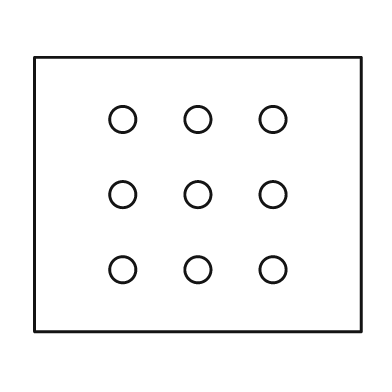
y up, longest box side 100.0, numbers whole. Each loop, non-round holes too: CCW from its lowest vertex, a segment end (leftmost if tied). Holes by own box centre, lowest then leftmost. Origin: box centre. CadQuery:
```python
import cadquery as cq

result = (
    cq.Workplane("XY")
    .moveTo(-50.0, -42.0)
    .lineTo(50.0, -42.0)
    .lineTo(50.0, 42.0)
    .lineTo(-50.0, 42.0)
    .close()
    .moveTo(-23.0, -23.0)
    .circle(4.0)
    .moveTo(0.0, -23.0)
    .circle(4.0)
    .moveTo(23.0, -23.0)
    .circle(4.0)
    .moveTo(-23.0, 0.0)
    .circle(4.0)
    .moveTo(0.0, 0.0)
    .circle(4.0)
    .moveTo(23.0, 0.0)
    .circle(4.0)
    .moveTo(-23.0, 23.0)
    .circle(4.0)
    .moveTo(0.0, 23.0)
    .circle(4.0)
    .moveTo(23.0, 23.0)
    .circle(4.0)
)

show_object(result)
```